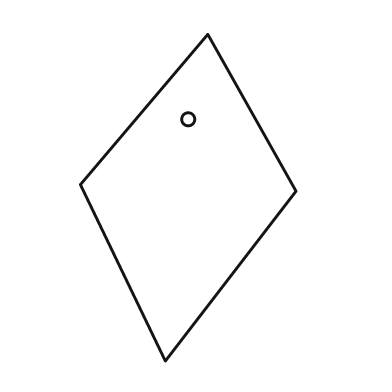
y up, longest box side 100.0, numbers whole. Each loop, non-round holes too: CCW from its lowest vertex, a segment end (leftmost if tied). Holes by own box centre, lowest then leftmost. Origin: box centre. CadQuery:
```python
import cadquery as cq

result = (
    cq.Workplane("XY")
    .moveTo(-7.0, -50.0)
    .lineTo(33.0, 2.0)
    .lineTo(6.0, 50.0)
    .lineTo(-33.0, 4.0)
    .close()
    .moveTo(0.0, 24.0)
    .circle(2.0)
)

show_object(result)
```